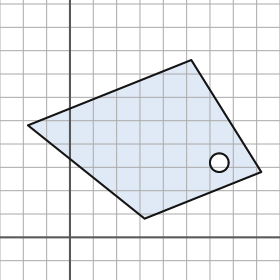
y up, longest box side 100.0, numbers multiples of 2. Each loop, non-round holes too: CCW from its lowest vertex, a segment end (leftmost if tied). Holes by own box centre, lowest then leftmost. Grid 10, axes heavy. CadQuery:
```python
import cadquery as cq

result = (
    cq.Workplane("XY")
    .moveTo(32.0, 8.0)
    .lineTo(82.0, 28.0)
    .lineTo(52.0, 76.0)
    .lineTo(-18.0, 48.0)
    .close()
    .moveTo(64.0, 32.0)
    .circle(4.0)
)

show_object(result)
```